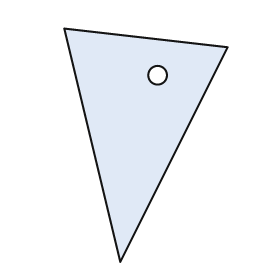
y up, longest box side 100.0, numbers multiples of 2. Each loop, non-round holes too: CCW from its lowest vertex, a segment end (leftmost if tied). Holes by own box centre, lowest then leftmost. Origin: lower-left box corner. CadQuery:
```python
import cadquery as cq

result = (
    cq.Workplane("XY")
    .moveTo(24.0, 0.0)
    .lineTo(70.0, 92.0)
    .lineTo(0.0, 100.0)
    .close()
    .moveTo(40.0, 80.0)
    .circle(4.0)
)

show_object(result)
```